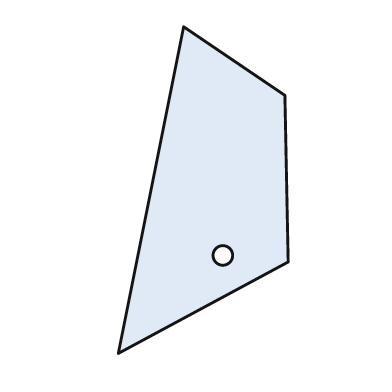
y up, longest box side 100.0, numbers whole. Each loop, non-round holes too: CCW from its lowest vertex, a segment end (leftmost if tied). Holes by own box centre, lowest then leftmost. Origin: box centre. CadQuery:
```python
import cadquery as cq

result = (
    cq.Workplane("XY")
    .moveTo(-26.0, -50.0)
    .lineTo(26.0, -22.0)
    .lineTo(25.0, 29.0)
    .lineTo(-6.0, 50.0)
    .close()
    .moveTo(6.0, -20.0)
    .circle(3.0)
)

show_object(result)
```